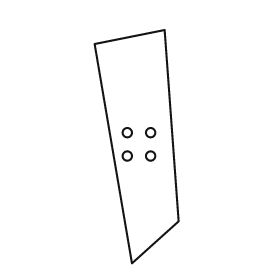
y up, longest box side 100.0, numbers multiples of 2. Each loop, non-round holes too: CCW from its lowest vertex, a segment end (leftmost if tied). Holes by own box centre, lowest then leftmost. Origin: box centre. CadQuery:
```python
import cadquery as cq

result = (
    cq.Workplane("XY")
    .moveTo(-2.0, -50.0)
    .lineTo(18.0, -32.0)
    .lineTo(12.0, 50.0)
    .lineTo(-18.0, 44.0)
    .close()
    .moveTo(-4.0, -4.0)
    .circle(2.0)
    .moveTo(6.0, -4.0)
    .circle(2.0)
    .moveTo(-4.0, 6.0)
    .circle(2.0)
    .moveTo(6.0, 6.0)
    .circle(2.0)
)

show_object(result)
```